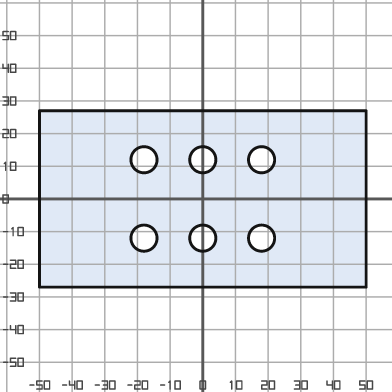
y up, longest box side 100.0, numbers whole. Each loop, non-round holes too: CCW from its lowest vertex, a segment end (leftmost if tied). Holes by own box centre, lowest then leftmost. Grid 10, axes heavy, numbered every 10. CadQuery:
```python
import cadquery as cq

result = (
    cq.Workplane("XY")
    .moveTo(-50.0, -27.0)
    .lineTo(50.0, -27.0)
    .lineTo(50.0, 27.0)
    .lineTo(-50.0, 27.0)
    .close()
    .moveTo(-18.0, -12.0)
    .circle(4.0)
    .moveTo(0.0, -12.0)
    .circle(4.0)
    .moveTo(18.0, -12.0)
    .circle(4.0)
    .moveTo(-18.0, 12.0)
    .circle(4.0)
    .moveTo(0.0, 12.0)
    .circle(4.0)
    .moveTo(18.0, 12.0)
    .circle(4.0)
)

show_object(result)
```